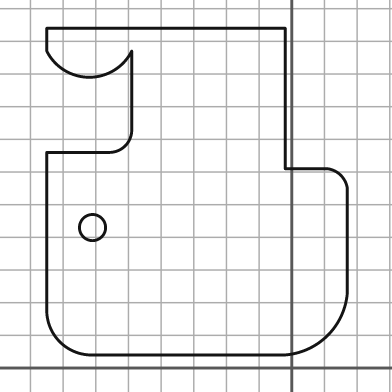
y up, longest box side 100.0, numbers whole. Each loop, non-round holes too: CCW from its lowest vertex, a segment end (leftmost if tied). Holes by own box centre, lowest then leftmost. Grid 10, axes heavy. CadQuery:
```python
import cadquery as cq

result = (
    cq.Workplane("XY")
    .moveTo(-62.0, 4.0)
    .lineTo(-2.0, 4.0)
    .threePointArc((11.0, 10.0), (17.0, 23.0))
    .lineTo(17.0, 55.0)
    .threePointArc((15.0, 59.0), (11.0, 61.0))
    .lineTo(-2.0, 61.0)
    .lineTo(-2.0, 104.0)
    .lineTo(-75.0, 104.0)
    .lineTo(-75.0, 97.0)
    .threePointArc((-62.0, 89.0), (-49.0, 97.0))
    .lineTo(-49.0, 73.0)
    .threePointArc((-51.0, 68.0), (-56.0, 66.0))
    .lineTo(-75.0, 66.0)
    .lineTo(-75.0, 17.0)
    .threePointArc((-71.0, 8.0), (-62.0, 4.0))
    .close()
    .moveTo(-61.0, 43.0)
    .circle(4.0)
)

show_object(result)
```